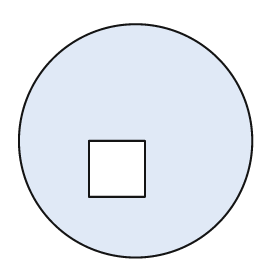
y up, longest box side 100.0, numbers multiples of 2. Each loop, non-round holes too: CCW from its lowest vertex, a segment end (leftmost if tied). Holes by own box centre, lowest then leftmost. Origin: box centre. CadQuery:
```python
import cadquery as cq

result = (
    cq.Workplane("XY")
    .moveTo(0.0, 0.0)
    .circle(50.0)
    .moveTo(-20.0, -24.0)
    .lineTo(4.0, -24.0)
    .lineTo(4.0, 0.0)
    .lineTo(-20.0, 0.0)
    .close()
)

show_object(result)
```